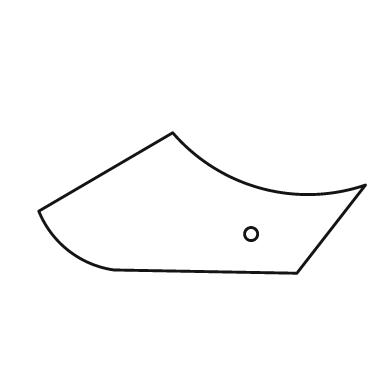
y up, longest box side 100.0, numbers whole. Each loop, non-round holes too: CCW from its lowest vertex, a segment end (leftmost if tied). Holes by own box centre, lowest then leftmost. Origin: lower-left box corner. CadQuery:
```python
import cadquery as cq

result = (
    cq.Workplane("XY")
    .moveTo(79.0, 0.0)
    .lineTo(100.0, 27.0)
    .threePointArc((68.0, 26.0), (41.0, 43.0))
    .lineTo(0.0, 19.0)
    .threePointArc((9.0, 7.0), (23.0, 1.0))
    .close()
    .moveTo(65.0, 12.0)
    .circle(2.0)
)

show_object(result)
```